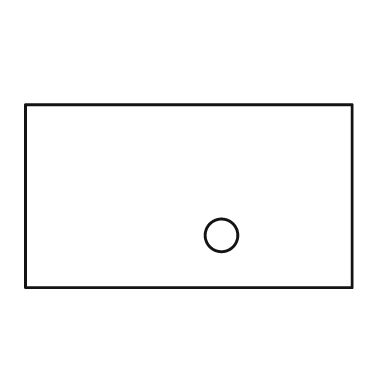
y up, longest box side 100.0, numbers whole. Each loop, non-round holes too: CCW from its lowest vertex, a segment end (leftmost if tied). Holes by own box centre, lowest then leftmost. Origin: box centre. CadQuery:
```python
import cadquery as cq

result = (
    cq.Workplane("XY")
    .moveTo(-50.0, -28.0)
    .lineTo(50.0, -28.0)
    .lineTo(50.0, 28.0)
    .lineTo(-50.0, 28.0)
    .close()
    .moveTo(10.0, -12.0)
    .circle(5.0)
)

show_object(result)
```